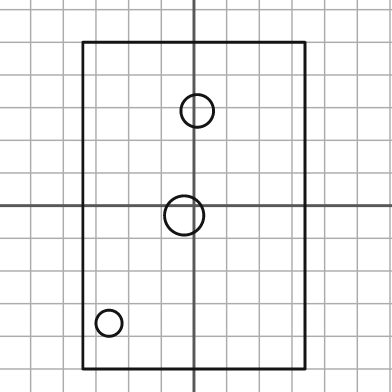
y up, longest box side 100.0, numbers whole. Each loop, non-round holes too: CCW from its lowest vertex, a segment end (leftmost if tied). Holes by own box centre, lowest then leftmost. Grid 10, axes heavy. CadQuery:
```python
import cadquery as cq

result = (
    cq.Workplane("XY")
    .moveTo(-34.0, -50.0)
    .lineTo(34.0, -50.0)
    .lineTo(34.0, 50.0)
    .lineTo(-34.0, 50.0)
    .close()
    .moveTo(-26.0, -36.0)
    .circle(4.0)
    .moveTo(-3.0, -3.0)
    .circle(6.0)
    .moveTo(1.0, 29.0)
    .circle(5.0)
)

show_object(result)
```